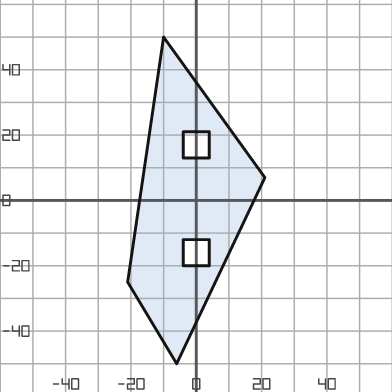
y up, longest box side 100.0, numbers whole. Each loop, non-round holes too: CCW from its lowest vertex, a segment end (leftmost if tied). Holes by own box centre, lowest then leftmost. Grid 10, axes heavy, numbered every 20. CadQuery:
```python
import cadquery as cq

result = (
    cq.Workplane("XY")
    .moveTo(-6.0, -50.0)
    .lineTo(21.0, 7.0)
    .lineTo(-10.0, 50.0)
    .lineTo(-21.0, -25.0)
    .close()
    .moveTo(-4.0, -20.0)
    .lineTo(4.0, -20.0)
    .lineTo(4.0, -12.0)
    .lineTo(-4.0, -12.0)
    .close()
    .moveTo(-4.0, 13.0)
    .lineTo(4.0, 13.0)
    .lineTo(4.0, 21.0)
    .lineTo(-4.0, 21.0)
    .close()
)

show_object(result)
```